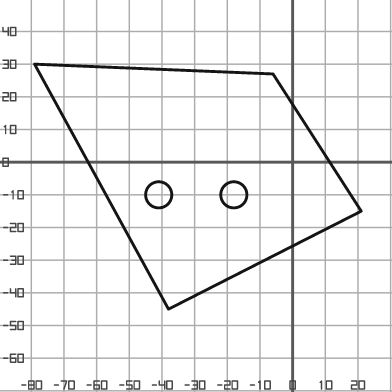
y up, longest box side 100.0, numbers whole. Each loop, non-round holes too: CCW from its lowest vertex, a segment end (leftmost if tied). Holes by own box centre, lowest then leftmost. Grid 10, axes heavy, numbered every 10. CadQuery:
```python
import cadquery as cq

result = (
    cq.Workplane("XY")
    .moveTo(-38.0, -45.0)
    .lineTo(21.0, -15.0)
    .lineTo(-6.0, 27.0)
    .lineTo(-79.0, 30.0)
    .close()
    .moveTo(-41.0, -10.0)
    .circle(4.0)
    .moveTo(-18.0, -10.0)
    .circle(4.0)
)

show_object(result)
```